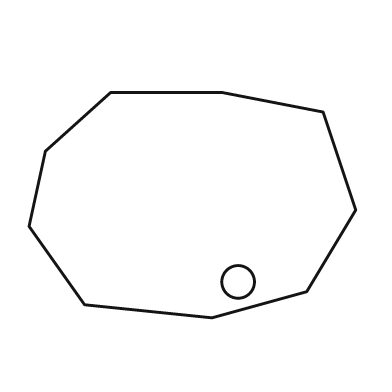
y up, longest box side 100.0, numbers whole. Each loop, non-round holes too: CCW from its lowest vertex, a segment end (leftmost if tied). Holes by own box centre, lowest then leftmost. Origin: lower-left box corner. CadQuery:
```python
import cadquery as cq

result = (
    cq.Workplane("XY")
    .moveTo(56.0, 0.0)
    .lineTo(85.0, 8.0)
    .lineTo(100.0, 33.0)
    .lineTo(90.0, 63.0)
    .lineTo(59.0, 69.0)
    .lineTo(25.0, 69.0)
    .lineTo(5.0, 51.0)
    .lineTo(0.0, 28.0)
    .lineTo(17.0, 4.0)
    .close()
    .moveTo(64.0, 11.0)
    .circle(5.0)
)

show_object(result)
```